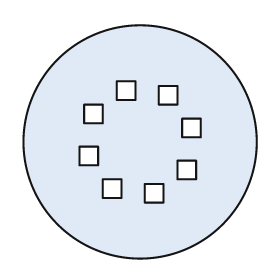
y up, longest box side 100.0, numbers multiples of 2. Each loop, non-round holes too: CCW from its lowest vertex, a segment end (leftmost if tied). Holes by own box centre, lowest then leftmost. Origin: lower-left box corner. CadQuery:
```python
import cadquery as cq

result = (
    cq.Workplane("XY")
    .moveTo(50.0, 50.0)
    .circle(50.0)
    .moveTo(52.0, 24.0)
    .lineTo(60.0, 24.0)
    .lineTo(60.0, 32.0)
    .lineTo(52.0, 32.0)
    .close()
    .moveTo(34.0, 26.0)
    .lineTo(42.0, 26.0)
    .lineTo(42.0, 34.0)
    .lineTo(34.0, 34.0)
    .close()
    .moveTo(66.0, 34.0)
    .lineTo(74.0, 34.0)
    .lineTo(74.0, 42.0)
    .lineTo(66.0, 42.0)
    .close()
    .moveTo(24.0, 40.0)
    .lineTo(32.0, 40.0)
    .lineTo(32.0, 48.0)
    .lineTo(24.0, 48.0)
    .close()
    .moveTo(68.0, 52.0)
    .lineTo(76.0, 52.0)
    .lineTo(76.0, 60.0)
    .lineTo(68.0, 60.0)
    .close()
    .moveTo(26.0, 58.0)
    .lineTo(34.0, 58.0)
    .lineTo(34.0, 66.0)
    .lineTo(26.0, 66.0)
    .close()
    .moveTo(58.0, 66.0)
    .lineTo(66.0, 66.0)
    .lineTo(66.0, 74.0)
    .lineTo(58.0, 74.0)
    .close()
    .moveTo(40.0, 68.0)
    .lineTo(48.0, 68.0)
    .lineTo(48.0, 76.0)
    .lineTo(40.0, 76.0)
    .close()
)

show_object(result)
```